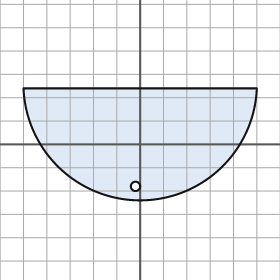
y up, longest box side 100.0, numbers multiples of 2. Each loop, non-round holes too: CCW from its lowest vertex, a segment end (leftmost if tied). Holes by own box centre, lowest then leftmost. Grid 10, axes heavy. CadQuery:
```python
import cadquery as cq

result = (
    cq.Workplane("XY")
    .moveTo(-50.0, 24.0)
    .threePointArc((0.0, -24.0), (50.0, 24.0))
    .close()
    .moveTo(-2.0, -18.0)
    .circle(2.0)
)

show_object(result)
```